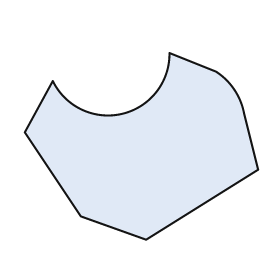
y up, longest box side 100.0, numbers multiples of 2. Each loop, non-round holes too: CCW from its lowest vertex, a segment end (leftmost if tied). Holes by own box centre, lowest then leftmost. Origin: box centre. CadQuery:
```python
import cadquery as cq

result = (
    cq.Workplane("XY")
    .moveTo(2.0, -40.0)
    .lineTo(50.0, -10.0)
    .lineTo(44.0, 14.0)
    .threePointArc((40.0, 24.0), (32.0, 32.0))
    .lineTo(12.0, 40.0)
    .threePointArc((-8.0, 14.0), (-38.0, 28.0))
    .lineTo(-50.0, 6.0)
    .lineTo(-26.0, -30.0)
    .close()
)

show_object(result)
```